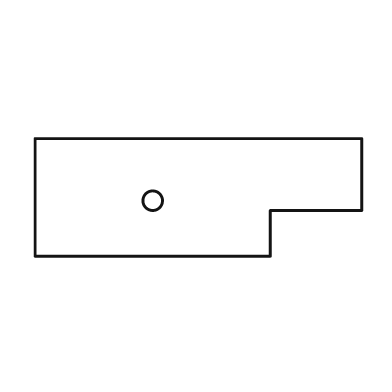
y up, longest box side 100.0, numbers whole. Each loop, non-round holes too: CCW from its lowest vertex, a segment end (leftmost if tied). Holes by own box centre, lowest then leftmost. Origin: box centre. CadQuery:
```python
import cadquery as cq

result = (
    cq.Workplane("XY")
    .moveTo(-50.0, -18.0)
    .lineTo(22.0, -18.0)
    .lineTo(22.0, -4.0)
    .lineTo(50.0, -4.0)
    .lineTo(50.0, 18.0)
    .lineTo(-50.0, 18.0)
    .close()
    .moveTo(-14.0, -1.0)
    .circle(3.0)
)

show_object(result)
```